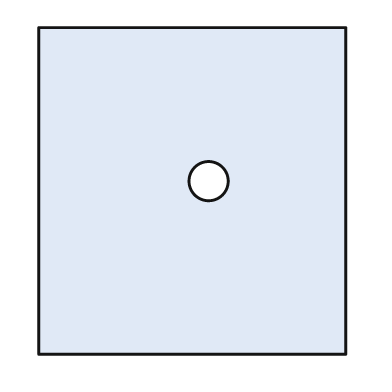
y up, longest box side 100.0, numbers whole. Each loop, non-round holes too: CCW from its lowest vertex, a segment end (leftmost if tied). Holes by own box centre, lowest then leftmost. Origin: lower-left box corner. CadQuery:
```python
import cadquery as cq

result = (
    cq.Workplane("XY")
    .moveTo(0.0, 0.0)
    .lineTo(94.0, 0.0)
    .lineTo(94.0, 100.0)
    .lineTo(0.0, 100.0)
    .close()
    .moveTo(52.0, 53.0)
    .circle(6.0)
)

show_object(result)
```